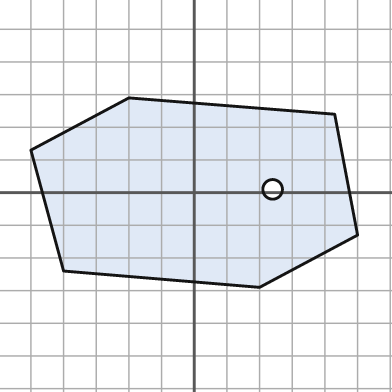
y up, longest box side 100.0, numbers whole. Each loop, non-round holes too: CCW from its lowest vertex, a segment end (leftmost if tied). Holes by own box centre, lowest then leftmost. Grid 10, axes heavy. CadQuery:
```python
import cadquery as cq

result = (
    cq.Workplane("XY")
    .moveTo(20.0, -29.0)
    .lineTo(50.0, -13.0)
    .lineTo(43.0, 24.0)
    .lineTo(-20.0, 29.0)
    .lineTo(-50.0, 13.0)
    .lineTo(-40.0, -24.0)
    .close()
    .moveTo(24.0, 1.0)
    .circle(3.0)
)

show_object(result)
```